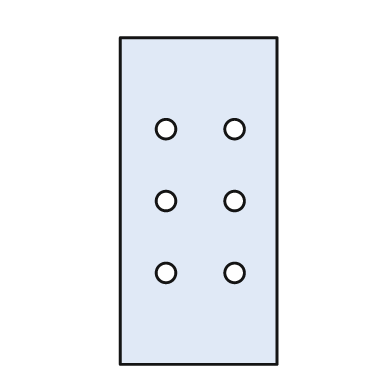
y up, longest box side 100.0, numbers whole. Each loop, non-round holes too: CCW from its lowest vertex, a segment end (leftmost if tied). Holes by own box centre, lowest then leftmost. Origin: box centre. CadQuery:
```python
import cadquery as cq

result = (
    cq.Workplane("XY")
    .moveTo(-24.0, -50.0)
    .lineTo(24.0, -50.0)
    .lineTo(24.0, 50.0)
    .lineTo(-24.0, 50.0)
    .close()
    .moveTo(-10.0, -22.0)
    .circle(3.0)
    .moveTo(11.0, -22.0)
    .circle(3.0)
    .moveTo(-10.0, 0.0)
    .circle(3.0)
    .moveTo(11.0, 0.0)
    .circle(3.0)
    .moveTo(-10.0, 22.0)
    .circle(3.0)
    .moveTo(11.0, 22.0)
    .circle(3.0)
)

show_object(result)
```